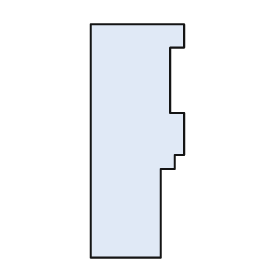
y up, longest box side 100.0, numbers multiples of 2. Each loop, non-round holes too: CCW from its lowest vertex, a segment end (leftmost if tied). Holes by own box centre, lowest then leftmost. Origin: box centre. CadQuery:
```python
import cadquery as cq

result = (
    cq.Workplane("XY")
    .moveTo(-20.0, -50.0)
    .lineTo(10.0, -50.0)
    .lineTo(10.0, -12.0)
    .lineTo(16.0, -12.0)
    .lineTo(16.0, -6.0)
    .lineTo(20.0, -6.0)
    .lineTo(20.0, 12.0)
    .lineTo(14.0, 12.0)
    .lineTo(14.0, 40.0)
    .lineTo(20.0, 40.0)
    .lineTo(20.0, 50.0)
    .lineTo(-20.0, 50.0)
    .close()
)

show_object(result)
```